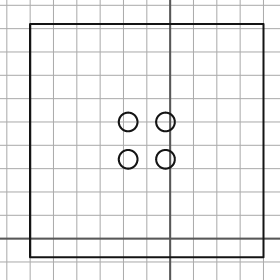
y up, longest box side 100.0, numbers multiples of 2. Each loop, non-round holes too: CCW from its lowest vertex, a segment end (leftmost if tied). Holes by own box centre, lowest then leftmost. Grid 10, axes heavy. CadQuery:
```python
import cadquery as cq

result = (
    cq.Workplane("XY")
    .moveTo(-60.0, -8.0)
    .lineTo(40.0, -8.0)
    .lineTo(40.0, 92.0)
    .lineTo(-60.0, 92.0)
    .close()
    .moveTo(-18.0, 34.0)
    .circle(4.0)
    .moveTo(-2.0, 34.0)
    .circle(4.0)
    .moveTo(-18.0, 50.0)
    .circle(4.0)
    .moveTo(-2.0, 50.0)
    .circle(4.0)
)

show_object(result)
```